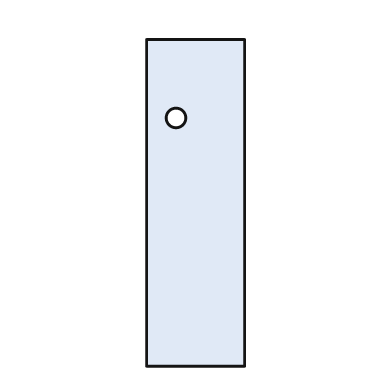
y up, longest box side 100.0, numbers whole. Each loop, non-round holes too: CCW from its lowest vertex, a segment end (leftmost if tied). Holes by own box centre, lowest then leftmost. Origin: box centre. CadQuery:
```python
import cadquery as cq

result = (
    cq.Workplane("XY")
    .moveTo(-15.0, -50.0)
    .lineTo(15.0, -50.0)
    .lineTo(15.0, 50.0)
    .lineTo(-15.0, 50.0)
    .close()
    .moveTo(-6.0, 26.0)
    .circle(3.0)
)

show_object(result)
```